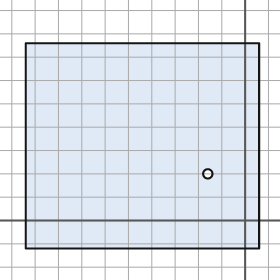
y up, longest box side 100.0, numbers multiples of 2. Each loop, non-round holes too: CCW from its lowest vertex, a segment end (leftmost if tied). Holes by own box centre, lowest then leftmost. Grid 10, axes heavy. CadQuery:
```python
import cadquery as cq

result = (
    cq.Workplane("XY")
    .moveTo(-94.0, -12.0)
    .lineTo(6.0, -12.0)
    .lineTo(6.0, 76.0)
    .lineTo(-94.0, 76.0)
    .close()
    .moveTo(-16.0, 20.0)
    .circle(2.0)
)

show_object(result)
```